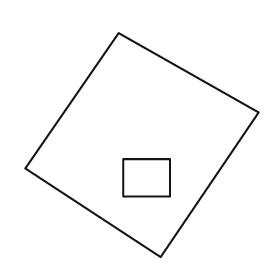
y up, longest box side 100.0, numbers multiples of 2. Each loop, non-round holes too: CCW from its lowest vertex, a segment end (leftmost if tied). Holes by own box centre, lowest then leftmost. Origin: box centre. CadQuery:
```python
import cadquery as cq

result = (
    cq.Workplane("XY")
    .moveTo(8.0, -48.0)
    .lineTo(50.0, 14.0)
    .lineTo(-10.0, 48.0)
    .lineTo(-50.0, -10.0)
    .close()
    .moveTo(-8.0, -22.0)
    .lineTo(12.0, -22.0)
    .lineTo(12.0, -6.0)
    .lineTo(-8.0, -6.0)
    .close()
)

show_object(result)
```